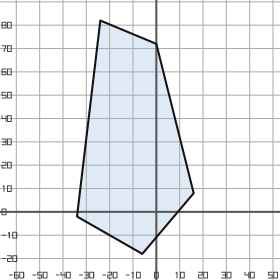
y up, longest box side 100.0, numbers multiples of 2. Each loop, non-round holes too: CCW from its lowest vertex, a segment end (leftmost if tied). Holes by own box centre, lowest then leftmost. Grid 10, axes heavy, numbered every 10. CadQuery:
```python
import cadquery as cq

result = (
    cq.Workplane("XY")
    .moveTo(-6.0, -18.0)
    .lineTo(16.0, 8.0)
    .lineTo(0.0, 72.0)
    .lineTo(-24.0, 82.0)
    .lineTo(-34.0, -2.0)
    .close()
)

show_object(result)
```